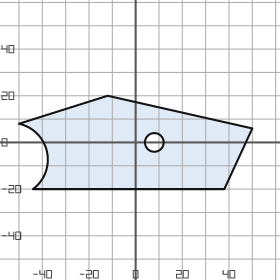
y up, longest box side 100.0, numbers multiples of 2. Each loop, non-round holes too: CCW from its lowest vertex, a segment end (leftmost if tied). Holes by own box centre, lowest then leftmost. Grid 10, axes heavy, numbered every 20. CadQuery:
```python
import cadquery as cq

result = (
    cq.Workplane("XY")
    .moveTo(-44.0, -20.0)
    .lineTo(38.0, -20.0)
    .lineTo(50.0, 6.0)
    .lineTo(-12.0, 20.0)
    .lineTo(-50.0, 8.0)
    .threePointArc((-38.0, -4.0), (-44.0, -20.0))
    .close()
    .moveTo(8.0, 0.0)
    .circle(4.0)
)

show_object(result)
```